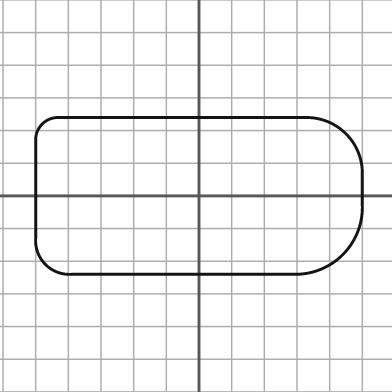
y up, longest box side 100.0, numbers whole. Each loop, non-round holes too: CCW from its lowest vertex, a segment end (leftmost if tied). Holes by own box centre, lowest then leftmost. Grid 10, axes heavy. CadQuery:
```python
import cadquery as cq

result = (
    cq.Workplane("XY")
    .moveTo(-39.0, -24.0)
    .lineTo(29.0, -24.0)
    .threePointArc((44.0, -18.0), (50.0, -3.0))
    .lineTo(50.0, 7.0)
    .threePointArc((45.0, 19.0), (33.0, 24.0))
    .lineTo(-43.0, 24.0)
    .threePointArc((-48.0, 22.0), (-50.0, 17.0))
    .lineTo(-50.0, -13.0)
    .threePointArc((-47.0, -21.0), (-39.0, -24.0))
    .close()
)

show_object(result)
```